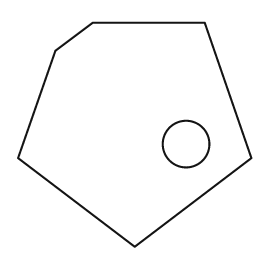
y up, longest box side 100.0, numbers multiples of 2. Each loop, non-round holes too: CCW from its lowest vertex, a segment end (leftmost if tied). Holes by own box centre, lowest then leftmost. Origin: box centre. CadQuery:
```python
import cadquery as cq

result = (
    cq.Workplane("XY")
    .moveTo(0.0, -48.0)
    .lineTo(50.0, -10.0)
    .lineTo(30.0, 48.0)
    .lineTo(-18.0, 48.0)
    .lineTo(-34.0, 36.0)
    .lineTo(-50.0, -10.0)
    .close()
    .moveTo(22.0, -4.0)
    .circle(10.0)
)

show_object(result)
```